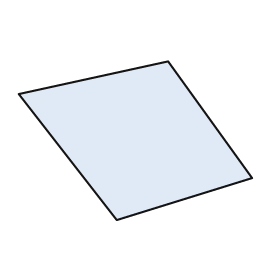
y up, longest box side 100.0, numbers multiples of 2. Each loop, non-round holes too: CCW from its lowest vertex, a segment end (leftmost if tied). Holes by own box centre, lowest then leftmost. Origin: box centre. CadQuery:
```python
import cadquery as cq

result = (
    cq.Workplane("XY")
    .moveTo(-8.0, -34.0)
    .lineTo(50.0, -16.0)
    .lineTo(14.0, 34.0)
    .lineTo(-50.0, 20.0)
    .close()
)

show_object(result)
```